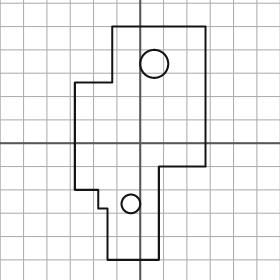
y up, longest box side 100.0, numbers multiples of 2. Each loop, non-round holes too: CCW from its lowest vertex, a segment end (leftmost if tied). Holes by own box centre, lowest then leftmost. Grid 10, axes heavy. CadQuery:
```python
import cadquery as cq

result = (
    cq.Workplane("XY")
    .moveTo(-14.0, -50.0)
    .lineTo(8.0, -50.0)
    .lineTo(8.0, -10.0)
    .lineTo(28.0, -10.0)
    .lineTo(28.0, 50.0)
    .lineTo(-12.0, 50.0)
    .lineTo(-12.0, 26.0)
    .lineTo(-28.0, 26.0)
    .lineTo(-28.0, -20.0)
    .lineTo(-18.0, -20.0)
    .lineTo(-18.0, -28.0)
    .lineTo(-14.0, -28.0)
    .close()
    .moveTo(-4.0, -26.0)
    .circle(4.0)
    .moveTo(6.0, 34.0)
    .circle(6.0)
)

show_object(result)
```